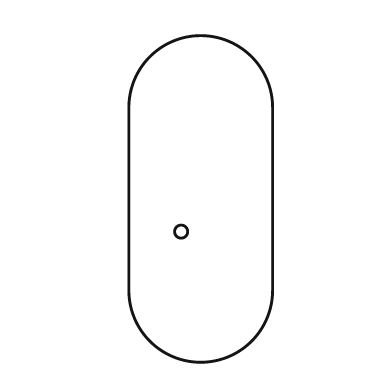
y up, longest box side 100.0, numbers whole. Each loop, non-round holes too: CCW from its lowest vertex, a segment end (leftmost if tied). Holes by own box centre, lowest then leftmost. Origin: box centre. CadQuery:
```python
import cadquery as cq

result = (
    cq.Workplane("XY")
    .moveTo(-22.0, -28.0)
    .threePointArc((0.0, -50.0), (22.0, -28.0))
    .lineTo(22.0, 28.0)
    .threePointArc((0.0, 50.0), (-22.0, 28.0))
    .close()
    .moveTo(-6.0, -10.0)
    .circle(2.0)
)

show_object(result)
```